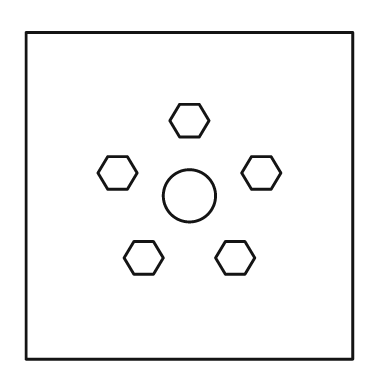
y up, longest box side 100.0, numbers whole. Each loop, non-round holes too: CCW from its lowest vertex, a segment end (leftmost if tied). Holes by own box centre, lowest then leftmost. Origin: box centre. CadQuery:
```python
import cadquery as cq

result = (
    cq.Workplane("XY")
    .moveTo(-50.0, -50.0)
    .lineTo(50.0, -50.0)
    .lineTo(50.0, 50.0)
    .lineTo(-50.0, 50.0)
    .close()
    .moveTo(-17.0, -24.0)
    .lineTo(-11.0, -24.0)
    .lineTo(-8.0, -19.0)
    .lineTo(-11.0, -14.0)
    .lineTo(-17.0, -14.0)
    .lineTo(-20.0, -19.0)
    .close()
    .moveTo(11.0, -24.0)
    .lineTo(17.0, -24.0)
    .lineTo(20.0, -19.0)
    .lineTo(17.0, -14.0)
    .lineTo(11.0, -14.0)
    .lineTo(8.0, -19.0)
    .close()
    .moveTo(0.0, 0.0)
    .circle(8.0)
    .moveTo(-25.0, 2.0)
    .lineTo(-19.0, 2.0)
    .lineTo(-16.0, 7.0)
    .lineTo(-19.0, 12.0)
    .lineTo(-25.0, 12.0)
    .lineTo(-28.0, 7.0)
    .close()
    .moveTo(19.0, 2.0)
    .lineTo(25.0, 2.0)
    .lineTo(28.0, 7.0)
    .lineTo(25.0, 12.0)
    .lineTo(19.0, 12.0)
    .lineTo(16.0, 7.0)
    .close()
    .moveTo(-3.0, 18.0)
    .lineTo(3.0, 18.0)
    .lineTo(6.0, 23.0)
    .lineTo(3.0, 28.0)
    .lineTo(-3.0, 28.0)
    .lineTo(-6.0, 23.0)
    .close()
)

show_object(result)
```